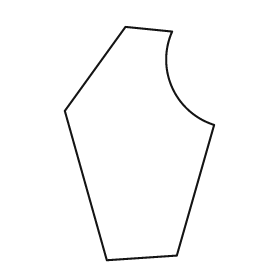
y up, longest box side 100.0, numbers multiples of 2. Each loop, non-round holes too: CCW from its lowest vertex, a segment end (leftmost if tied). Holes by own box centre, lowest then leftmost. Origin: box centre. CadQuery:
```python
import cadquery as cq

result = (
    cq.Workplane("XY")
    .moveTo(-14.0, -50.0)
    .lineTo(16.0, -48.0)
    .lineTo(32.0, 8.0)
    .threePointArc((14.0, 24.0), (14.0, 48.0))
    .lineTo(-6.0, 50.0)
    .lineTo(-32.0, 14.0)
    .close()
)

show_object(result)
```